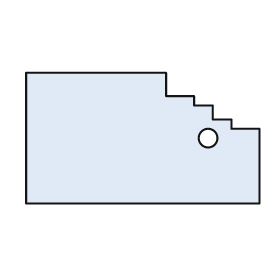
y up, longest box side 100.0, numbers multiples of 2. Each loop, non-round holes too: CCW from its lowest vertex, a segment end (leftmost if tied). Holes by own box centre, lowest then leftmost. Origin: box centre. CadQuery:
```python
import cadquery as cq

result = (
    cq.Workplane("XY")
    .moveTo(-50.0, -28.0)
    .lineTo(50.0, -28.0)
    .lineTo(50.0, 4.0)
    .lineTo(38.0, 4.0)
    .lineTo(38.0, 8.0)
    .lineTo(30.0, 8.0)
    .lineTo(30.0, 14.0)
    .lineTo(22.0, 14.0)
    .lineTo(22.0, 18.0)
    .lineTo(10.0, 18.0)
    .lineTo(10.0, 28.0)
    .lineTo(-50.0, 28.0)
    .close()
    .moveTo(28.0, 0.0)
    .circle(4.0)
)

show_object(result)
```